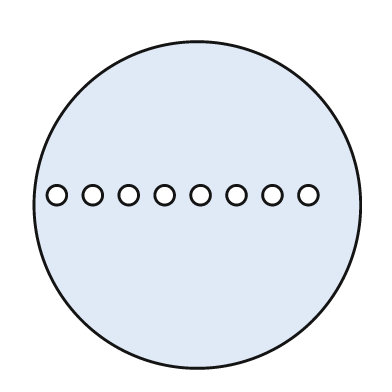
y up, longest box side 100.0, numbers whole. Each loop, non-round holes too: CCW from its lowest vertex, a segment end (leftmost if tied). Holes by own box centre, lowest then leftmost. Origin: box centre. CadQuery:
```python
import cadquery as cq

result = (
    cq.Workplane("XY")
    .moveTo(0.0, 0.0)
    .circle(50.0)
    .moveTo(-43.0, 3.0)
    .circle(3.0)
    .moveTo(-32.0, 3.0)
    .circle(3.0)
    .moveTo(-21.0, 3.0)
    .circle(3.0)
    .moveTo(-10.0, 3.0)
    .circle(3.0)
    .moveTo(1.0, 3.0)
    .circle(3.0)
    .moveTo(12.0, 3.0)
    .circle(3.0)
    .moveTo(23.0, 3.0)
    .circle(3.0)
    .moveTo(34.0, 3.0)
    .circle(3.0)
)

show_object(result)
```